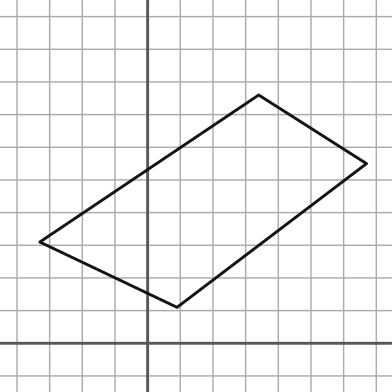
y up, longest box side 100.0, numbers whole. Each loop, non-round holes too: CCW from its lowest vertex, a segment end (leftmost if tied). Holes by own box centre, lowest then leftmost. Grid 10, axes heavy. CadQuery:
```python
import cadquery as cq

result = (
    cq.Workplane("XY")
    .moveTo(9.0, 11.0)
    .lineTo(67.0, 55.0)
    .lineTo(34.0, 76.0)
    .lineTo(-33.0, 31.0)
    .close()
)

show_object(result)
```